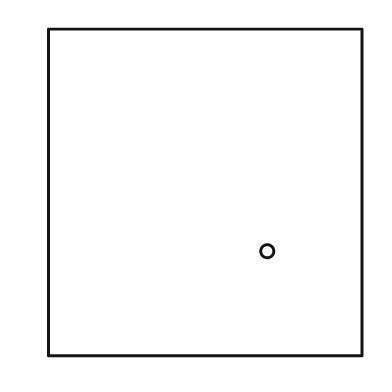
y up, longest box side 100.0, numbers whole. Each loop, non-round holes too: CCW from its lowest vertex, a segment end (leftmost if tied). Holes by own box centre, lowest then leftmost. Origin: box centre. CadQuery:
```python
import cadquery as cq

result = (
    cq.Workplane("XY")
    .moveTo(-48.0, -50.0)
    .lineTo(48.0, -50.0)
    .lineTo(48.0, 50.0)
    .lineTo(-48.0, 50.0)
    .close()
    .moveTo(19.0, -18.0)
    .circle(2.0)
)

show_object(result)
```